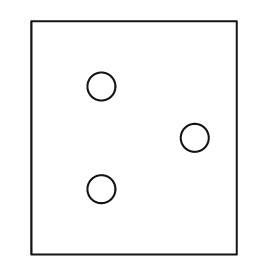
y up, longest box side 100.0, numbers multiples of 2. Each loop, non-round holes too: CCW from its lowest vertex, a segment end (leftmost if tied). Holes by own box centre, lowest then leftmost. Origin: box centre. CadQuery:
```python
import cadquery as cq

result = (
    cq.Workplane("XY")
    .moveTo(-44.0, -50.0)
    .lineTo(44.0, -50.0)
    .lineTo(44.0, 50.0)
    .lineTo(-44.0, 50.0)
    .close()
    .moveTo(-14.0, -22.0)
    .circle(6.0)
    .moveTo(26.0, 0.0)
    .circle(6.0)
    .moveTo(-14.0, 22.0)
    .circle(6.0)
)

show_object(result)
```